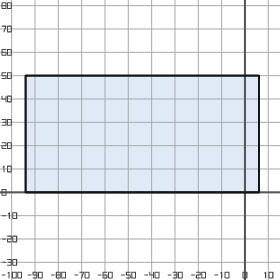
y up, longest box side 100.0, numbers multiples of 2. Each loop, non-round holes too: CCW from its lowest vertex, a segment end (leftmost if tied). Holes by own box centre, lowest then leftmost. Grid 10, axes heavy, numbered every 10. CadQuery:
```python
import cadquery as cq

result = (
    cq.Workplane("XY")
    .moveTo(-94.0, 0.0)
    .lineTo(6.0, 0.0)
    .lineTo(6.0, 50.0)
    .lineTo(-94.0, 50.0)
    .close()
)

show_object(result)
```